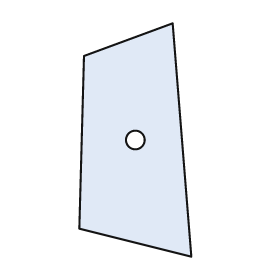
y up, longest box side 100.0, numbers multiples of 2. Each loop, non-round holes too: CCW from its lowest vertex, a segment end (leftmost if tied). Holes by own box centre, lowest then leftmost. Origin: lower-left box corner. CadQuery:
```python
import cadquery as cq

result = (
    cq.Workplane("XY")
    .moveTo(48.0, 0.0)
    .lineTo(40.0, 100.0)
    .lineTo(2.0, 86.0)
    .lineTo(0.0, 12.0)
    .close()
    .moveTo(24.0, 50.0)
    .circle(4.0)
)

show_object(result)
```